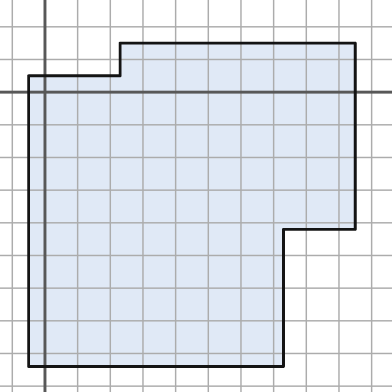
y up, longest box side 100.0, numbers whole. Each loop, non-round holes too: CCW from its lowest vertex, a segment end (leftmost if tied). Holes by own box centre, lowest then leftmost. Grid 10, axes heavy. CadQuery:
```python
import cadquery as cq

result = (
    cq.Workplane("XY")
    .moveTo(-5.0, -84.0)
    .lineTo(73.0, -84.0)
    .lineTo(73.0, -42.0)
    .lineTo(95.0, -42.0)
    .lineTo(95.0, 15.0)
    .lineTo(23.0, 15.0)
    .lineTo(23.0, 5.0)
    .lineTo(-5.0, 5.0)
    .close()
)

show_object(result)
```